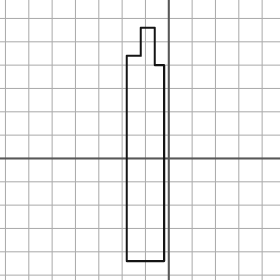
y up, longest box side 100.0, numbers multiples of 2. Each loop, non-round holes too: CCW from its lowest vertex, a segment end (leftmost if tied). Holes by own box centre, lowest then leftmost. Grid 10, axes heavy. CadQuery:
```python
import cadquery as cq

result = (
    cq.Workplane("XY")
    .moveTo(-18.0, -44.0)
    .lineTo(-2.0, -44.0)
    .lineTo(-2.0, 40.0)
    .lineTo(-6.0, 40.0)
    .lineTo(-6.0, 56.0)
    .lineTo(-12.0, 56.0)
    .lineTo(-12.0, 44.0)
    .lineTo(-18.0, 44.0)
    .close()
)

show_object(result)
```